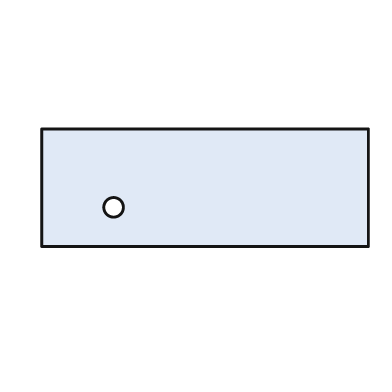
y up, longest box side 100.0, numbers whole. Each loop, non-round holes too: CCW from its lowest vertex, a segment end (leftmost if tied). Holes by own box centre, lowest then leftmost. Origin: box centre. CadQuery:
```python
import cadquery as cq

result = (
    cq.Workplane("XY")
    .moveTo(-50.0, -18.0)
    .lineTo(50.0, -18.0)
    .lineTo(50.0, 18.0)
    .lineTo(-50.0, 18.0)
    .close()
    .moveTo(-28.0, -6.0)
    .circle(3.0)
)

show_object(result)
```